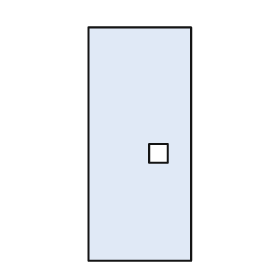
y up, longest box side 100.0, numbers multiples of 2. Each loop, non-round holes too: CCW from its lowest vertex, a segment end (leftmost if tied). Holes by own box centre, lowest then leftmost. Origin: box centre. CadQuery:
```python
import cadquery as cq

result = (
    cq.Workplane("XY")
    .moveTo(-22.0, -50.0)
    .lineTo(22.0, -50.0)
    .lineTo(22.0, 50.0)
    .lineTo(-22.0, 50.0)
    .close()
    .moveTo(4.0, -8.0)
    .lineTo(12.0, -8.0)
    .lineTo(12.0, 0.0)
    .lineTo(4.0, 0.0)
    .close()
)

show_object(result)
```